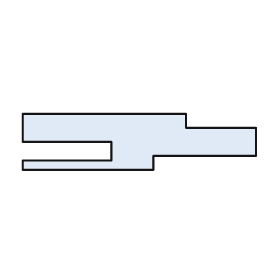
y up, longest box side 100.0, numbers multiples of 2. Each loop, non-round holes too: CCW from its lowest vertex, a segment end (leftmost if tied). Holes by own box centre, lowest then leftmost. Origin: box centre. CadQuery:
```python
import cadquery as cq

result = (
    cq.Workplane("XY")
    .moveTo(-50.0, -12.0)
    .lineTo(6.0, -12.0)
    .lineTo(6.0, -6.0)
    .lineTo(50.0, -6.0)
    .lineTo(50.0, 6.0)
    .lineTo(20.0, 6.0)
    .lineTo(20.0, 12.0)
    .lineTo(-50.0, 12.0)
    .lineTo(-50.0, 0.0)
    .lineTo(-12.0, 0.0)
    .lineTo(-12.0, -8.0)
    .lineTo(-50.0, -8.0)
    .close()
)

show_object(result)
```